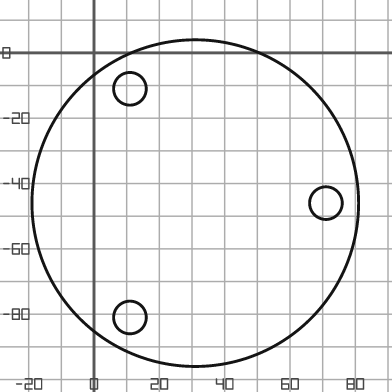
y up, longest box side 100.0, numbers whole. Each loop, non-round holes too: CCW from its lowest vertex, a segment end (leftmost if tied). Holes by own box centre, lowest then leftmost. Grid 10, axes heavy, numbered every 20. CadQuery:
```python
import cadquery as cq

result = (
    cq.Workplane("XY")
    .moveTo(31.0, -46.0)
    .circle(50.0)
    .moveTo(11.0, -81.0)
    .circle(5.0)
    .moveTo(71.0, -46.0)
    .circle(5.0)
    .moveTo(11.0, -11.0)
    .circle(5.0)
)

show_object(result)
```